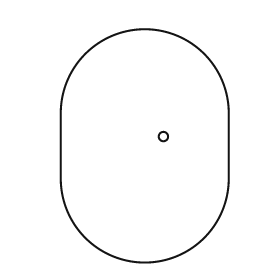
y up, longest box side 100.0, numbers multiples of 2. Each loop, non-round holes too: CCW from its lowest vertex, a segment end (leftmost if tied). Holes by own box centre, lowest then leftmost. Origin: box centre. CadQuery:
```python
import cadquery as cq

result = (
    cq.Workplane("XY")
    .moveTo(-36.0, -14.0)
    .threePointArc((0.0, -50.0), (36.0, -14.0))
    .lineTo(36.0, 14.0)
    .threePointArc((0.0, 50.0), (-36.0, 14.0))
    .close()
    .moveTo(8.0, 4.0)
    .circle(2.0)
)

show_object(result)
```